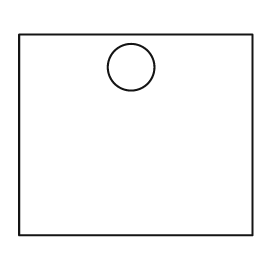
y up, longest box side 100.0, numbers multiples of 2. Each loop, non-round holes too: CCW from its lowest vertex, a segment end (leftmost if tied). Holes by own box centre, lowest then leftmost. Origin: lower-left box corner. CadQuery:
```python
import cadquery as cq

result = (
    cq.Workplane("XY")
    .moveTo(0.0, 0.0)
    .lineTo(100.0, 0.0)
    .lineTo(100.0, 86.0)
    .lineTo(0.0, 86.0)
    .close()
    .moveTo(48.0, 72.0)
    .circle(10.0)
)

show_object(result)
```